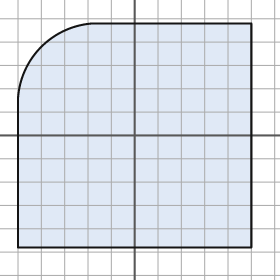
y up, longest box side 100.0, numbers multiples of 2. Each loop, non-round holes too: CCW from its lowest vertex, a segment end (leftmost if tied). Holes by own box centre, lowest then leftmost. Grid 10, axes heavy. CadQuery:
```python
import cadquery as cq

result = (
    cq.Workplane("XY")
    .moveTo(-50.0, -48.0)
    .lineTo(50.0, -48.0)
    .lineTo(50.0, 48.0)
    .lineTo(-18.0, 48.0)
    .threePointArc((-40.0, 38.0), (-50.0, 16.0))
    .close()
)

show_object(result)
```